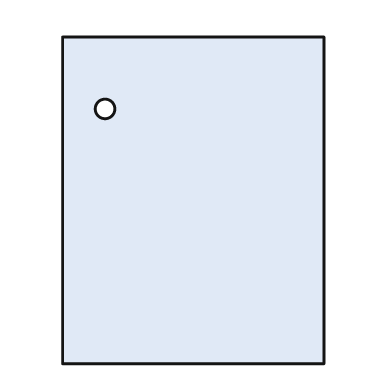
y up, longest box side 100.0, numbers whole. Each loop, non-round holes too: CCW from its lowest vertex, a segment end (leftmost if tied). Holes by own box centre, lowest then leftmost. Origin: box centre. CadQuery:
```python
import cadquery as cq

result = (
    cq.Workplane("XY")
    .moveTo(-40.0, -50.0)
    .lineTo(40.0, -50.0)
    .lineTo(40.0, 50.0)
    .lineTo(-40.0, 50.0)
    .close()
    .moveTo(-27.0, 28.0)
    .circle(3.0)
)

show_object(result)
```